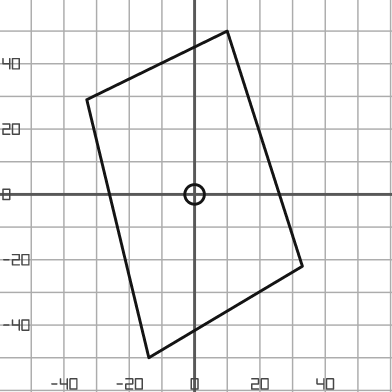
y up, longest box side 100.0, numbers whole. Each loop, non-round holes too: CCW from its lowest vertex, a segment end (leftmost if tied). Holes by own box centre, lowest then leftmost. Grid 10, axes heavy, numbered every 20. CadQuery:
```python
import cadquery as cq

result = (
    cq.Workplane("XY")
    .moveTo(-14.0, -50.0)
    .lineTo(33.0, -22.0)
    .lineTo(10.0, 50.0)
    .lineTo(-33.0, 29.0)
    .close()
    .moveTo(0.0, 0.0)
    .circle(3.0)
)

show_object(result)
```